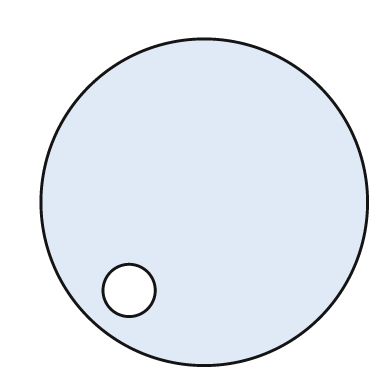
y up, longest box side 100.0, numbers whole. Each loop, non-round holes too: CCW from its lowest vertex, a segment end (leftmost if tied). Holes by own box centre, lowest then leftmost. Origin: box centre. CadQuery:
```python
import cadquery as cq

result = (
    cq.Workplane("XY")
    .moveTo(0.0, 0.0)
    .circle(50.0)
    .moveTo(-23.0, -27.0)
    .circle(8.0)
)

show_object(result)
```